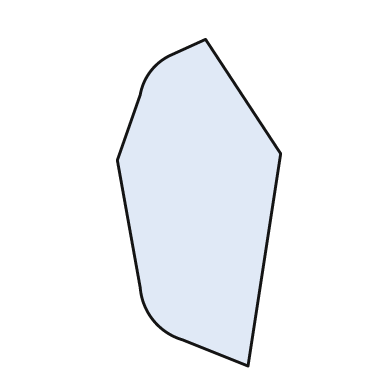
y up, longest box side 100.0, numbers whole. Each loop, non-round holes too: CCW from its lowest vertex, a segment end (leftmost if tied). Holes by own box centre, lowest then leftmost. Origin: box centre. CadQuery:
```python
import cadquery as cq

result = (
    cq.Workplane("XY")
    .moveTo(15.0, -50.0)
    .lineTo(25.0, 15.0)
    .lineTo(2.0, 50.0)
    .lineTo(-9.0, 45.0)
    .threePointArc((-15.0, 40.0), (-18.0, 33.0))
    .lineTo(-25.0, 13.0)
    .lineTo(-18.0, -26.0)
    .threePointArc((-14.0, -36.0), (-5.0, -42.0))
    .close()
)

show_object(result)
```